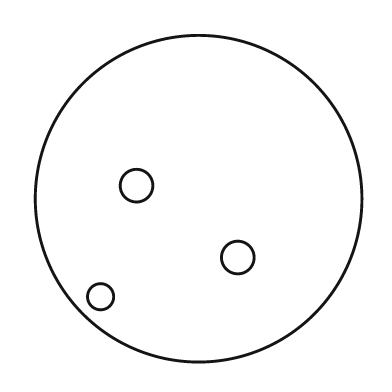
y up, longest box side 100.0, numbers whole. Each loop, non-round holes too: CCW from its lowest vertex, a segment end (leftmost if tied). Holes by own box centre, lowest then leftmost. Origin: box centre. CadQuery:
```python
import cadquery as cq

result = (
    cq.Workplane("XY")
    .moveTo(0.0, 0.0)
    .circle(50.0)
    .moveTo(-30.0, -30.0)
    .circle(4.0)
    .moveTo(12.0, -18.0)
    .circle(5.0)
    .moveTo(-19.0, 4.0)
    .circle(5.0)
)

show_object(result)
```